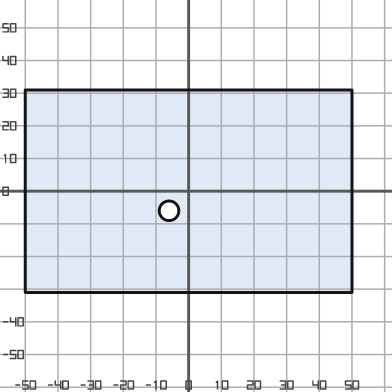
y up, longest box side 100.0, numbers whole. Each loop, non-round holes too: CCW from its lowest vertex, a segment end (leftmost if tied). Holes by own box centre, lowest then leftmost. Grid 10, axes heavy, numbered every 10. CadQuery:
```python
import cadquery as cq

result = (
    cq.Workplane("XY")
    .moveTo(-50.0, -31.0)
    .lineTo(50.0, -31.0)
    .lineTo(50.0, 31.0)
    .lineTo(-50.0, 31.0)
    .close()
    .moveTo(-6.0, -6.0)
    .circle(3.0)
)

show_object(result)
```